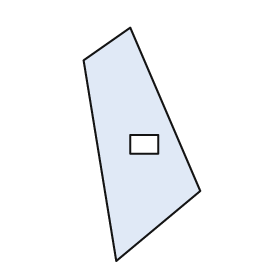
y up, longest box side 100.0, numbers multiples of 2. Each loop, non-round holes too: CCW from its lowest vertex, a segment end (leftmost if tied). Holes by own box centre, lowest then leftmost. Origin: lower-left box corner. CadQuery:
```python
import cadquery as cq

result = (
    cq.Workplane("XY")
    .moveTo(14.0, 0.0)
    .lineTo(50.0, 30.0)
    .lineTo(20.0, 100.0)
    .lineTo(0.0, 86.0)
    .close()
    .moveTo(20.0, 46.0)
    .lineTo(32.0, 46.0)
    .lineTo(32.0, 54.0)
    .lineTo(20.0, 54.0)
    .close()
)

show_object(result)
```